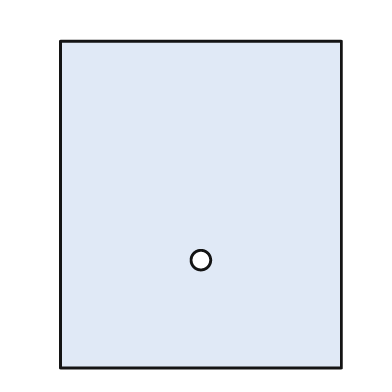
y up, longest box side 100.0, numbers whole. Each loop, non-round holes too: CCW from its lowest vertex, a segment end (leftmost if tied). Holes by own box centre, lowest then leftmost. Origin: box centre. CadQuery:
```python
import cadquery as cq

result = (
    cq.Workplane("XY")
    .moveTo(-43.0, -50.0)
    .lineTo(43.0, -50.0)
    .lineTo(43.0, 50.0)
    .lineTo(-43.0, 50.0)
    .close()
    .moveTo(0.0, -17.0)
    .circle(3.0)
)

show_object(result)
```